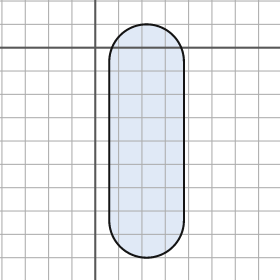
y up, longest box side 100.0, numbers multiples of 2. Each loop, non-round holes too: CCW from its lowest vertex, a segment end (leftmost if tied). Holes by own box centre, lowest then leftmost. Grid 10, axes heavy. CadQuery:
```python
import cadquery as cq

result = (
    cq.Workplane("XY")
    .moveTo(6.0, -74.0)
    .threePointArc((22.0, -90.0), (38.0, -74.0))
    .lineTo(38.0, -6.0)
    .threePointArc((22.0, 10.0), (6.0, -6.0))
    .close()
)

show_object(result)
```